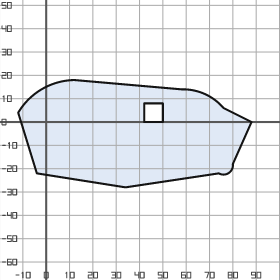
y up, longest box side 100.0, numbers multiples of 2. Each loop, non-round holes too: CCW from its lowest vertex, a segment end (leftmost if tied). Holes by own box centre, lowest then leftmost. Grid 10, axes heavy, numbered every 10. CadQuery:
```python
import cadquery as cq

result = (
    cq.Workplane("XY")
    .moveTo(34.0, -28.0)
    .lineTo(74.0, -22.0)
    .threePointArc((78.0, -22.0), (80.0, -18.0))
    .lineTo(88.0, 0.0)
    .lineTo(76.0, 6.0)
    .threePointArc((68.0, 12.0), (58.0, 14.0))
    .lineTo(12.0, 18.0)
    .threePointArc((-2.0, 14.0), (-12.0, 4.0))
    .lineTo(-4.0, -22.0)
    .close()
    .moveTo(42.0, 0.0)
    .lineTo(50.0, 0.0)
    .lineTo(50.0, 8.0)
    .lineTo(42.0, 8.0)
    .close()
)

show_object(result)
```